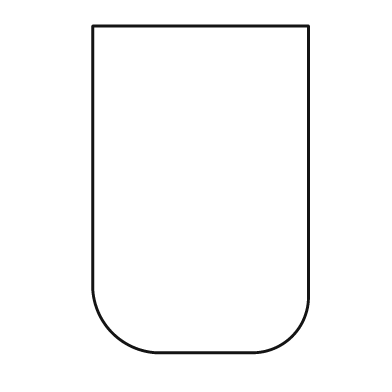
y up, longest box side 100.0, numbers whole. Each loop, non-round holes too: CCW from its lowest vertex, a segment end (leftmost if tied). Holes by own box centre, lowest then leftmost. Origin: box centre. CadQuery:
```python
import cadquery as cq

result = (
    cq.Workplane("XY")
    .moveTo(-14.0, -50.0)
    .lineTo(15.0, -50.0)
    .threePointArc((28.0, -45.0), (33.0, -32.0))
    .lineTo(33.0, 50.0)
    .lineTo(-33.0, 50.0)
    .lineTo(-33.0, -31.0)
    .threePointArc((-27.0, -44.0), (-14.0, -50.0))
    .close()
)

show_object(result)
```